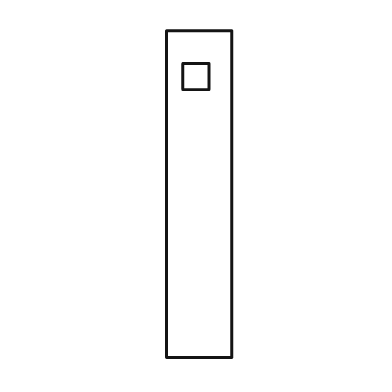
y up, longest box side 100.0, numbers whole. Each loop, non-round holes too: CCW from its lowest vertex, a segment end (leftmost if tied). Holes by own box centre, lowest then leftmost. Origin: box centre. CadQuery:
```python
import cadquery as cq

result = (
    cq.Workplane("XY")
    .moveTo(-10.0, -50.0)
    .lineTo(10.0, -50.0)
    .lineTo(10.0, 50.0)
    .lineTo(-10.0, 50.0)
    .close()
    .moveTo(-5.0, 32.0)
    .lineTo(3.0, 32.0)
    .lineTo(3.0, 40.0)
    .lineTo(-5.0, 40.0)
    .close()
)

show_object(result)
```